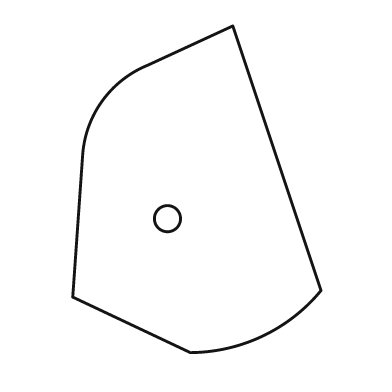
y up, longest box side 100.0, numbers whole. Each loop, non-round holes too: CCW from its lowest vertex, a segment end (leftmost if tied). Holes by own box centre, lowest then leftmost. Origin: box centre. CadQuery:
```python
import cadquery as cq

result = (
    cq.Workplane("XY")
    .moveTo(-2.0, -50.0)
    .threePointArc((20.0, -45.0), (38.0, -31.0))
    .lineTo(11.0, 50.0)
    .lineTo(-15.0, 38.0)
    .threePointArc((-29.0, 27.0), (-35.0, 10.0))
    .lineTo(-38.0, -33.0)
    .close()
    .moveTo(-9.0, -9.0)
    .circle(4.0)
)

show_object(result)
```